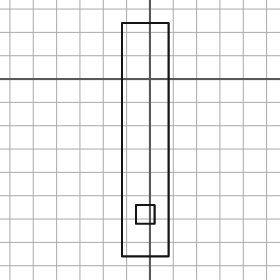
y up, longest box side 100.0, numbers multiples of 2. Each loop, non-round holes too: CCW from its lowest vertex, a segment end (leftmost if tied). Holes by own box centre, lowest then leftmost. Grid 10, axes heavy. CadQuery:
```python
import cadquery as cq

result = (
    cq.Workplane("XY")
    .moveTo(-12.0, -76.0)
    .lineTo(8.0, -76.0)
    .lineTo(8.0, 24.0)
    .lineTo(-12.0, 24.0)
    .close()
    .moveTo(-6.0, -62.0)
    .lineTo(2.0, -62.0)
    .lineTo(2.0, -54.0)
    .lineTo(-6.0, -54.0)
    .close()
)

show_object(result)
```